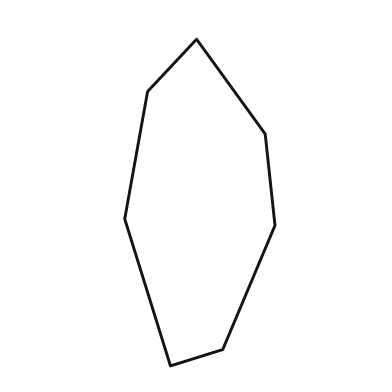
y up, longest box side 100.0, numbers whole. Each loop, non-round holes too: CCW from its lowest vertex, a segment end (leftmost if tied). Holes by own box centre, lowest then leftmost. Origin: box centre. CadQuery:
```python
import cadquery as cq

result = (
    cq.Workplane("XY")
    .moveTo(-9.0, -50.0)
    .lineTo(7.0, -45.0)
    .lineTo(23.0, -7.0)
    .lineTo(20.0, 21.0)
    .lineTo(-1.0, 50.0)
    .lineTo(-16.0, 34.0)
    .lineTo(-23.0, -5.0)
    .close()
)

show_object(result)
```